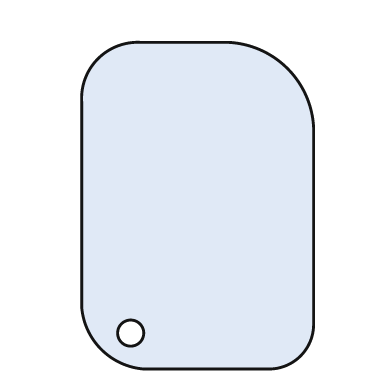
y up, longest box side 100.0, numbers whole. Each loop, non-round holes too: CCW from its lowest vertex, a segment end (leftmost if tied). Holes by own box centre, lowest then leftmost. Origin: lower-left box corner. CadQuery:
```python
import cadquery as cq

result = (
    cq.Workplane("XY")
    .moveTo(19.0, 0.0)
    .lineTo(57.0, 0.0)
    .threePointArc((67.0, 4.0), (71.0, 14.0))
    .lineTo(71.0, 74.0)
    .threePointArc((63.0, 92.0), (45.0, 100.0))
    .lineTo(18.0, 100.0)
    .threePointArc((5.0, 95.0), (0.0, 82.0))
    .lineTo(0.0, 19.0)
    .threePointArc((6.0, 6.0), (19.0, 0.0))
    .close()
    .moveTo(15.0, 11.0)
    .circle(4.0)
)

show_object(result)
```